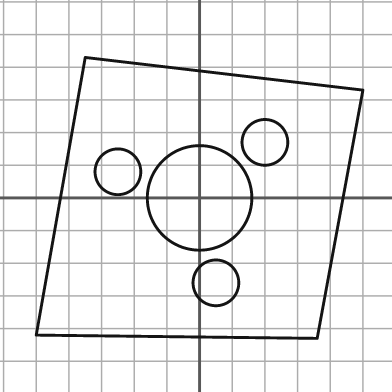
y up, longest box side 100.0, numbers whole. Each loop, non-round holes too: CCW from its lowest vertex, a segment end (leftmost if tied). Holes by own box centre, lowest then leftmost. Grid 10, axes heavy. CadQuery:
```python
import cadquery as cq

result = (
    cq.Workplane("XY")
    .moveTo(36.0, -43.0)
    .lineTo(50.0, 33.0)
    .lineTo(-35.0, 43.0)
    .lineTo(-50.0, -42.0)
    .close()
    .moveTo(5.0, -26.0)
    .circle(7.0)
    .moveTo(0.0, 0.0)
    .circle(16.0)
    .moveTo(-25.0, 8.0)
    .circle(7.0)
    .moveTo(20.0, 17.0)
    .circle(7.0)
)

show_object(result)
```